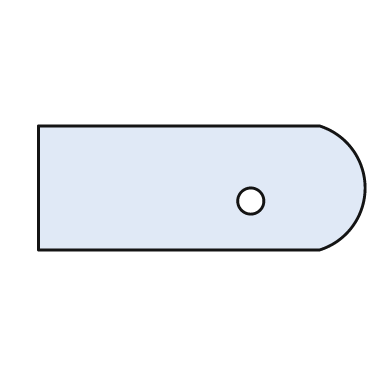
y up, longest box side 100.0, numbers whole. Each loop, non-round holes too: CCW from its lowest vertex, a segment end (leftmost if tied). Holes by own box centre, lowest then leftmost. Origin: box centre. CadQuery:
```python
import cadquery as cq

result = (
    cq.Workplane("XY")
    .moveTo(-50.0, -19.0)
    .lineTo(36.0, -19.0)
    .threePointArc((50.0, 0.0), (36.0, 19.0))
    .lineTo(-50.0, 19.0)
    .close()
    .moveTo(15.0, -4.0)
    .circle(4.0)
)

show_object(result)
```